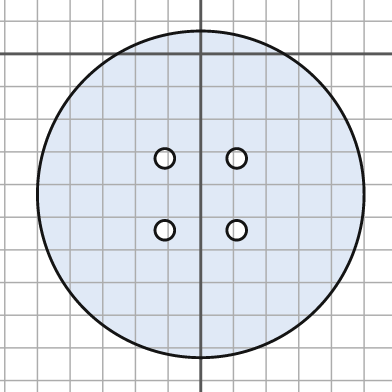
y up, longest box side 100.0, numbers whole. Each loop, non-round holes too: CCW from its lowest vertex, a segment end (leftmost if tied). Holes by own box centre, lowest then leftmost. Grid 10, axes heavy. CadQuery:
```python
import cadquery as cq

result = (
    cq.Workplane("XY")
    .moveTo(0.0, -43.0)
    .circle(50.0)
    .moveTo(-11.0, -54.0)
    .circle(3.0)
    .moveTo(11.0, -54.0)
    .circle(3.0)
    .moveTo(-11.0, -32.0)
    .circle(3.0)
    .moveTo(11.0, -32.0)
    .circle(3.0)
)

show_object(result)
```